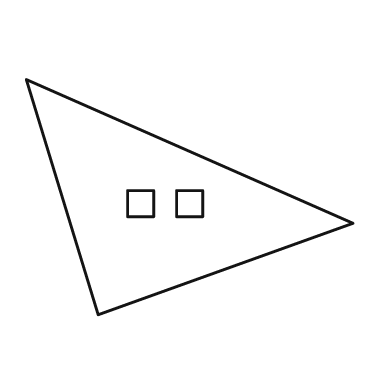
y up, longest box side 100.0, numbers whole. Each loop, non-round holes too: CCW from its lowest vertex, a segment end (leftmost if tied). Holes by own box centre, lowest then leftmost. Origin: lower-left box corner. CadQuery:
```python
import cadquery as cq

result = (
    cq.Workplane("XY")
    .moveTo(22.0, 0.0)
    .lineTo(100.0, 28.0)
    .lineTo(0.0, 72.0)
    .close()
    .moveTo(31.0, 30.0)
    .lineTo(39.0, 30.0)
    .lineTo(39.0, 38.0)
    .lineTo(31.0, 38.0)
    .close()
    .moveTo(46.0, 30.0)
    .lineTo(54.0, 30.0)
    .lineTo(54.0, 38.0)
    .lineTo(46.0, 38.0)
    .close()
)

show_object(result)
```